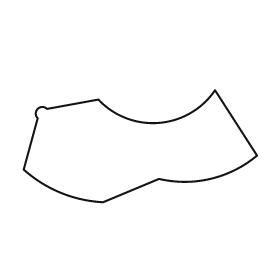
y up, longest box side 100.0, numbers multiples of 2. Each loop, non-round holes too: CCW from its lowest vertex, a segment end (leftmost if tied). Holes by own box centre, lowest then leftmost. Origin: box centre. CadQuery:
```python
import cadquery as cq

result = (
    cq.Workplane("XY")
    .moveTo(-16.0, -24.0)
    .lineTo(8.0, -14.0)
    .threePointArc((30.0, -14.0), (50.0, -4.0))
    .lineTo(32.0, 24.0)
    .threePointArc((8.0, 10.0), (-18.0, 20.0))
    .lineTo(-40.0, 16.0)
    .threePointArc((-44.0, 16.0), (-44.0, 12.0))
    .lineTo(-50.0, -10.0)
    .threePointArc((-34.0, -20.0), (-16.0, -24.0))
    .close()
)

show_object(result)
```